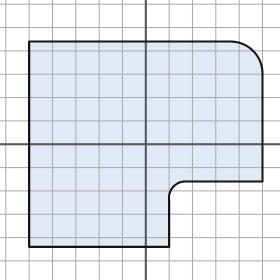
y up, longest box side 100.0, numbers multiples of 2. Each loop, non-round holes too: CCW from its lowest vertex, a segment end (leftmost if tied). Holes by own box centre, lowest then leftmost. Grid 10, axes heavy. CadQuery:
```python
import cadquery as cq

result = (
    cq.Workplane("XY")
    .moveTo(-50.0, -44.0)
    .lineTo(10.0, -44.0)
    .lineTo(10.0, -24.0)
    .threePointArc((12.0, -18.0), (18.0, -16.0))
    .lineTo(50.0, -16.0)
    .lineTo(50.0, 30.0)
    .threePointArc((46.0, 40.0), (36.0, 44.0))
    .lineTo(-50.0, 44.0)
    .close()
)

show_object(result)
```